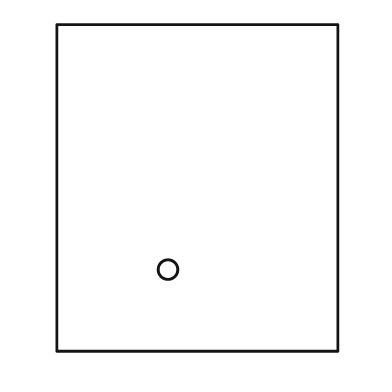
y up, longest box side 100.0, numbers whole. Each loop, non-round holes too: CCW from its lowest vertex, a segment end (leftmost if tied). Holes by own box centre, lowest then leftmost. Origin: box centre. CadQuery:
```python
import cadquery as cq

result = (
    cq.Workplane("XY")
    .moveTo(-43.0, -50.0)
    .lineTo(43.0, -50.0)
    .lineTo(43.0, 50.0)
    .lineTo(-43.0, 50.0)
    .close()
    .moveTo(-9.0, -25.0)
    .circle(3.0)
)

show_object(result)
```